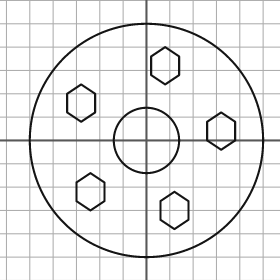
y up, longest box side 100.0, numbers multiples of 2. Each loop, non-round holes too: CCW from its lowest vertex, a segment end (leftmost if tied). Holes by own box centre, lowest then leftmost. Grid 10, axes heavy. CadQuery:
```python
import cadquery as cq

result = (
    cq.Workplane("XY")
    .moveTo(0.0, 0.0)
    .circle(50.0)
    .moveTo(12.0, -38.0)
    .lineTo(18.0, -34.0)
    .lineTo(18.0, -26.0)
    .lineTo(12.0, -22.0)
    .lineTo(6.0, -26.0)
    .lineTo(6.0, -34.0)
    .close()
    .moveTo(-24.0, -30.0)
    .lineTo(-18.0, -26.0)
    .lineTo(-18.0, -18.0)
    .lineTo(-24.0, -14.0)
    .lineTo(-30.0, -18.0)
    .lineTo(-30.0, -26.0)
    .close()
    .moveTo(0.0, 0.0)
    .circle(14.0)
    .moveTo(32.0, -4.0)
    .lineTo(38.0, 0.0)
    .lineTo(38.0, 8.0)
    .lineTo(32.0, 12.0)
    .lineTo(26.0, 8.0)
    .lineTo(26.0, 0.0)
    .close()
    .moveTo(-28.0, 8.0)
    .lineTo(-22.0, 12.0)
    .lineTo(-22.0, 20.0)
    .lineTo(-28.0, 24.0)
    .lineTo(-34.0, 20.0)
    .lineTo(-34.0, 12.0)
    .close()
    .moveTo(8.0, 24.0)
    .lineTo(14.0, 28.0)
    .lineTo(14.0, 36.0)
    .lineTo(8.0, 40.0)
    .lineTo(2.0, 36.0)
    .lineTo(2.0, 28.0)
    .close()
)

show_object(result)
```